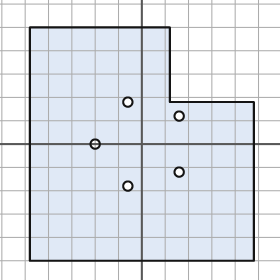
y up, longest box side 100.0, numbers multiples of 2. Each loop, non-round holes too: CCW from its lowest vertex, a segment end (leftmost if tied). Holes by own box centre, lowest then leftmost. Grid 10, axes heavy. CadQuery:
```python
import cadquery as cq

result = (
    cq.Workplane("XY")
    .moveTo(-48.0, -50.0)
    .lineTo(48.0, -50.0)
    .lineTo(48.0, 18.0)
    .lineTo(12.0, 18.0)
    .lineTo(12.0, 50.0)
    .lineTo(-48.0, 50.0)
    .close()
    .moveTo(-6.0, -18.0)
    .circle(2.0)
    .moveTo(16.0, -12.0)
    .circle(2.0)
    .moveTo(-20.0, 0.0)
    .circle(2.0)
    .moveTo(16.0, 12.0)
    .circle(2.0)
    .moveTo(-6.0, 18.0)
    .circle(2.0)
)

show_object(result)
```